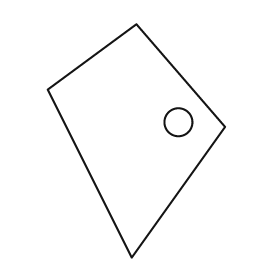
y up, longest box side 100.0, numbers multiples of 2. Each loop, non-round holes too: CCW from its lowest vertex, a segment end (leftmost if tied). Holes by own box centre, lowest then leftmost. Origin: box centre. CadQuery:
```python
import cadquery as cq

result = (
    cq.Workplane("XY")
    .moveTo(-2.0, -50.0)
    .lineTo(38.0, 6.0)
    .lineTo(0.0, 50.0)
    .lineTo(-38.0, 22.0)
    .close()
    .moveTo(18.0, 8.0)
    .circle(6.0)
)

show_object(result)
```